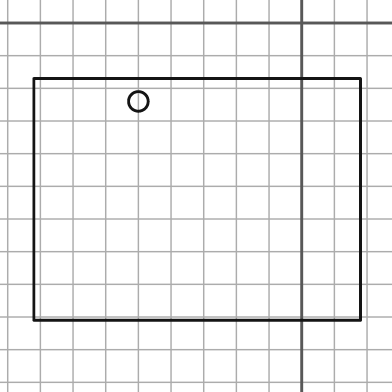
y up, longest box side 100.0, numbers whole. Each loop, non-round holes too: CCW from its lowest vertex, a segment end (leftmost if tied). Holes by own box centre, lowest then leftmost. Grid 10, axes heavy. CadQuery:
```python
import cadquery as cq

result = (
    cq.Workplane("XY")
    .moveTo(-82.0, -91.0)
    .lineTo(18.0, -91.0)
    .lineTo(18.0, -17.0)
    .lineTo(-82.0, -17.0)
    .close()
    .moveTo(-50.0, -24.0)
    .circle(3.0)
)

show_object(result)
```